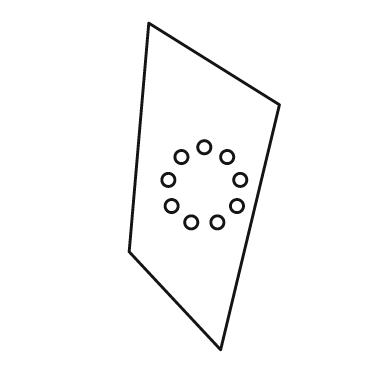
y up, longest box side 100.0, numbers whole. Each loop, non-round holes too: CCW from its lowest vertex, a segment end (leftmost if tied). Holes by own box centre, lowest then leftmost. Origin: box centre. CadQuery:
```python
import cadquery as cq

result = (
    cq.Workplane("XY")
    .moveTo(5.0, -50.0)
    .lineTo(23.0, 25.0)
    .lineTo(-17.0, 50.0)
    .lineTo(-23.0, -20.0)
    .close()
    .moveTo(-4.0, -11.0)
    .circle(2.0)
    .moveTo(4.0, -11.0)
    .circle(2.0)
    .moveTo(-10.0, -6.0)
    .circle(2.0)
    .moveTo(10.0, -6.0)
    .circle(2.0)
    .moveTo(-11.0, 2.0)
    .circle(2.0)
    .moveTo(11.0, 2.0)
    .circle(2.0)
    .moveTo(-7.0, 9.0)
    .circle(2.0)
    .moveTo(7.0, 9.0)
    .circle(2.0)
    .moveTo(0.0, 12.0)
    .circle(2.0)
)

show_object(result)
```